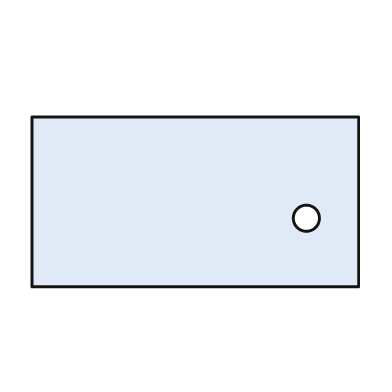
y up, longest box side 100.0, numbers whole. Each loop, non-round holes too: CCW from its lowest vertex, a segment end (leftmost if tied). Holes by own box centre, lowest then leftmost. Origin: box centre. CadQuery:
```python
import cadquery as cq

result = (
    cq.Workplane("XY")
    .moveTo(-50.0, -26.0)
    .lineTo(50.0, -26.0)
    .lineTo(50.0, 26.0)
    .lineTo(-50.0, 26.0)
    .close()
    .moveTo(34.0, -5.0)
    .circle(4.0)
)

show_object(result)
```